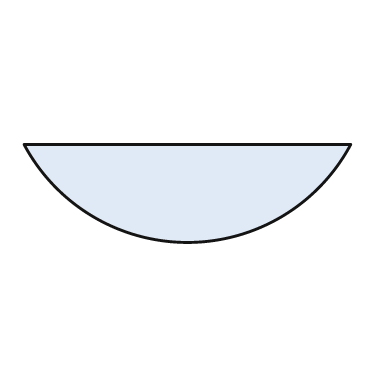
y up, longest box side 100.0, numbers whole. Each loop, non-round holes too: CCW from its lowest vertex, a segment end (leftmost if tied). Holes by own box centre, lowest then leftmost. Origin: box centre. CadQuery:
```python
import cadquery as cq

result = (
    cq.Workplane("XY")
    .moveTo(-50.0, 15.0)
    .threePointArc((0.0, -15.0), (50.0, 15.0))
    .close()
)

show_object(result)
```